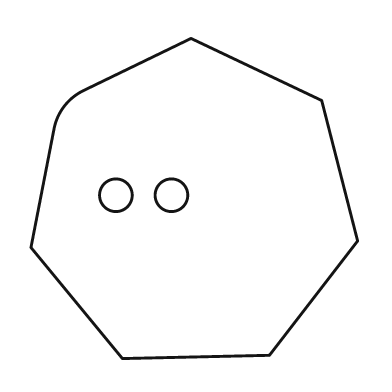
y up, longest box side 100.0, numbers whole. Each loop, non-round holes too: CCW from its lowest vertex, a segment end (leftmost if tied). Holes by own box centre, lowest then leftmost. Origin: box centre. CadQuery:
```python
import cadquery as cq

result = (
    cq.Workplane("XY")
    .moveTo(-22.0, -49.0)
    .lineTo(23.0, -48.0)
    .lineTo(50.0, -13.0)
    .lineTo(39.0, 30.0)
    .lineTo(-1.0, 49.0)
    .lineTo(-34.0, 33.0)
    .threePointArc((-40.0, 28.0), (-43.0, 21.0))
    .lineTo(-50.0, -15.0)
    .close()
    .moveTo(-24.0, 1.0)
    .circle(5.0)
    .moveTo(-7.0, 1.0)
    .circle(5.0)
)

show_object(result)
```